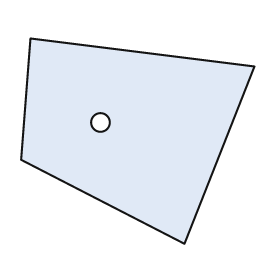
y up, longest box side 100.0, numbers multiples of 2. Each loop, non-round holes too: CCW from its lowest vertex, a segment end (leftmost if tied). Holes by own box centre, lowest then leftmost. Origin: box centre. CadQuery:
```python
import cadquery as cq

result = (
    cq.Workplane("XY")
    .moveTo(20.0, -44.0)
    .lineTo(50.0, 32.0)
    .lineTo(-46.0, 44.0)
    .lineTo(-50.0, -8.0)
    .close()
    .moveTo(-16.0, 8.0)
    .circle(4.0)
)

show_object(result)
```